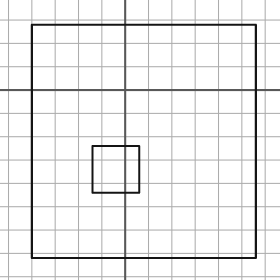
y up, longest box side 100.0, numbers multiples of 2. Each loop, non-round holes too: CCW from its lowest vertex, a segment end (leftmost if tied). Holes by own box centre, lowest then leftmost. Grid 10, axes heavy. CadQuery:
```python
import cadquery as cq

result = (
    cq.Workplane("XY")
    .moveTo(-40.0, -72.0)
    .lineTo(56.0, -72.0)
    .lineTo(56.0, 28.0)
    .lineTo(-40.0, 28.0)
    .close()
    .moveTo(-14.0, -44.0)
    .lineTo(6.0, -44.0)
    .lineTo(6.0, -24.0)
    .lineTo(-14.0, -24.0)
    .close()
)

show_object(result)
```